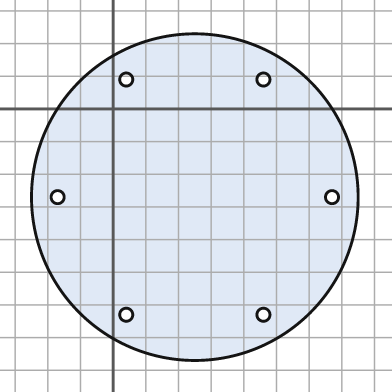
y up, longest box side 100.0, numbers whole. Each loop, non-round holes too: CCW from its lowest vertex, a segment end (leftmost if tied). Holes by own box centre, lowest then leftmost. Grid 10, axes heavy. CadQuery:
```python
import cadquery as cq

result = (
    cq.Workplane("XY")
    .moveTo(25.0, -27.0)
    .circle(50.0)
    .moveTo(4.0, -63.0)
    .circle(2.0)
    .moveTo(46.0, -63.0)
    .circle(2.0)
    .moveTo(-17.0, -27.0)
    .circle(2.0)
    .moveTo(67.0, -27.0)
    .circle(2.0)
    .moveTo(4.0, 9.0)
    .circle(2.0)
    .moveTo(46.0, 9.0)
    .circle(2.0)
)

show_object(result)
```